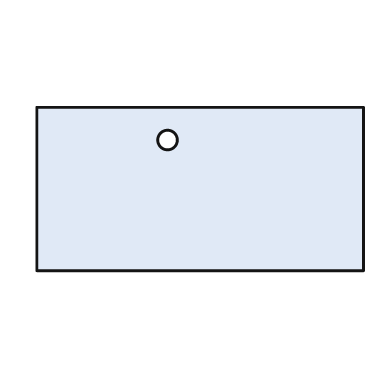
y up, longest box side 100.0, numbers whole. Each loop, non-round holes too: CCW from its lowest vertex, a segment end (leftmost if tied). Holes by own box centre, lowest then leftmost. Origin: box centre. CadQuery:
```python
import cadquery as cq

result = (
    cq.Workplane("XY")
    .moveTo(-50.0, -25.0)
    .lineTo(50.0, -25.0)
    .lineTo(50.0, 25.0)
    .lineTo(-50.0, 25.0)
    .close()
    .moveTo(-10.0, 15.0)
    .circle(3.0)
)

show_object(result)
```